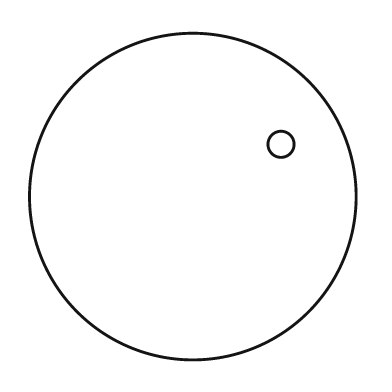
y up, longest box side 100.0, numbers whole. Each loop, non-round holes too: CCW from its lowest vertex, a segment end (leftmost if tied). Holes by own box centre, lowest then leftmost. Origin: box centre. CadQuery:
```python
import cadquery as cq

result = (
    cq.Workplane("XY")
    .moveTo(0.0, 0.0)
    .circle(50.0)
    .moveTo(27.0, 16.0)
    .circle(4.0)
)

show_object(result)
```